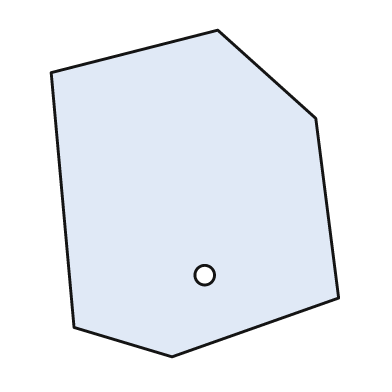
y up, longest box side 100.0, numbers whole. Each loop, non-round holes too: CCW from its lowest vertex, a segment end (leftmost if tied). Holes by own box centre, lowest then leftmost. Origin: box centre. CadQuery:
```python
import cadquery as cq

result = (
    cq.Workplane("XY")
    .moveTo(-7.0, -50.0)
    .lineTo(44.0, -32.0)
    .lineTo(37.0, 23.0)
    .lineTo(7.0, 50.0)
    .lineTo(-44.0, 37.0)
    .lineTo(-37.0, -41.0)
    .close()
    .moveTo(3.0, -25.0)
    .circle(3.0)
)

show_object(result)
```